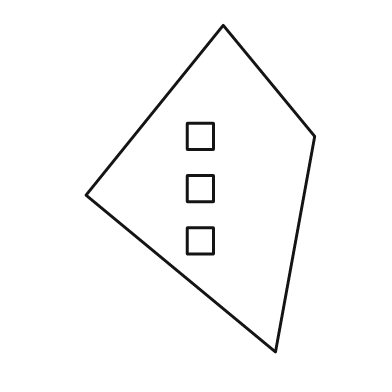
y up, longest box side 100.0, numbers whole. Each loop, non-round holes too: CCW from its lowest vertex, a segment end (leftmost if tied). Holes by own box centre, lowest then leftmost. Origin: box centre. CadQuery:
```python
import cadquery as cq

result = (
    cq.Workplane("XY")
    .moveTo(23.0, -50.0)
    .lineTo(35.0, 16.0)
    .lineTo(7.0, 50.0)
    .lineTo(-35.0, -2.0)
    .close()
    .moveTo(-4.0, -20.0)
    .lineTo(4.0, -20.0)
    .lineTo(4.0, -12.0)
    .lineTo(-4.0, -12.0)
    .close()
    .moveTo(-4.0, -4.0)
    .lineTo(4.0, -4.0)
    .lineTo(4.0, 4.0)
    .lineTo(-4.0, 4.0)
    .close()
    .moveTo(-4.0, 12.0)
    .lineTo(4.0, 12.0)
    .lineTo(4.0, 20.0)
    .lineTo(-4.0, 20.0)
    .close()
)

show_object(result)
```